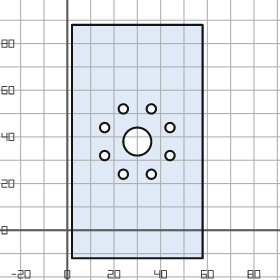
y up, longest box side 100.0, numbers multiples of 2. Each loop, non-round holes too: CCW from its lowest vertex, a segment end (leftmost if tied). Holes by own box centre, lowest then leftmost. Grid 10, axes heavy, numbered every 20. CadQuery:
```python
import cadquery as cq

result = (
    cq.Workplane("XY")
    .moveTo(2.0, -12.0)
    .lineTo(58.0, -12.0)
    .lineTo(58.0, 88.0)
    .lineTo(2.0, 88.0)
    .close()
    .moveTo(24.0, 24.0)
    .circle(2.0)
    .moveTo(36.0, 24.0)
    .circle(2.0)
    .moveTo(16.0, 32.0)
    .circle(2.0)
    .moveTo(44.0, 32.0)
    .circle(2.0)
    .moveTo(30.0, 38.0)
    .circle(6.0)
    .moveTo(16.0, 44.0)
    .circle(2.0)
    .moveTo(44.0, 44.0)
    .circle(2.0)
    .moveTo(24.0, 52.0)
    .circle(2.0)
    .moveTo(36.0, 52.0)
    .circle(2.0)
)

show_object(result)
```